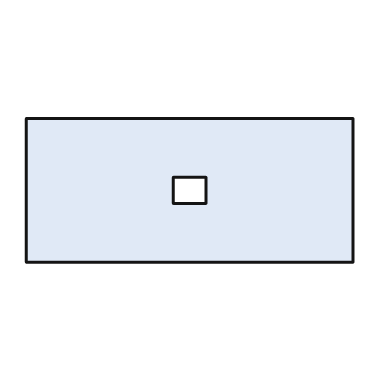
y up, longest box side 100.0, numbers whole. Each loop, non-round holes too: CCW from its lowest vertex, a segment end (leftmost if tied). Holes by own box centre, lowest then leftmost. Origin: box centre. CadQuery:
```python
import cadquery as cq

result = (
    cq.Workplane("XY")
    .moveTo(-50.0, -22.0)
    .lineTo(50.0, -22.0)
    .lineTo(50.0, 22.0)
    .lineTo(-50.0, 22.0)
    .close()
    .moveTo(-5.0, -4.0)
    .lineTo(5.0, -4.0)
    .lineTo(5.0, 4.0)
    .lineTo(-5.0, 4.0)
    .close()
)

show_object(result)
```